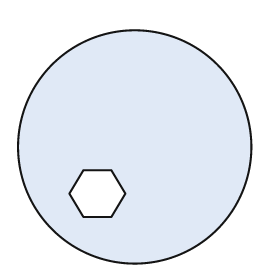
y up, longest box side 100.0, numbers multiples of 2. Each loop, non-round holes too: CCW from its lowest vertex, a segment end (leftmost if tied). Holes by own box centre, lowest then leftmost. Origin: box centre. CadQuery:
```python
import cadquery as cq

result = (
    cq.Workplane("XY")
    .moveTo(0.0, 0.0)
    .circle(50.0)
    .moveTo(-22.0, -30.0)
    .lineTo(-10.0, -30.0)
    .lineTo(-4.0, -20.0)
    .lineTo(-10.0, -10.0)
    .lineTo(-22.0, -10.0)
    .lineTo(-28.0, -20.0)
    .close()
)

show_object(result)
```